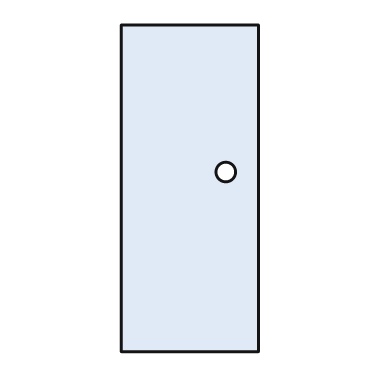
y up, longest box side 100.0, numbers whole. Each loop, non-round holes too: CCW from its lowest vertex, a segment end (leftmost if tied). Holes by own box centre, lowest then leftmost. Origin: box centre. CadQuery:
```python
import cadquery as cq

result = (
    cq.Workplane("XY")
    .moveTo(-21.0, -50.0)
    .lineTo(21.0, -50.0)
    .lineTo(21.0, 50.0)
    .lineTo(-21.0, 50.0)
    .close()
    .moveTo(11.0, 5.0)
    .circle(3.0)
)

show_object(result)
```